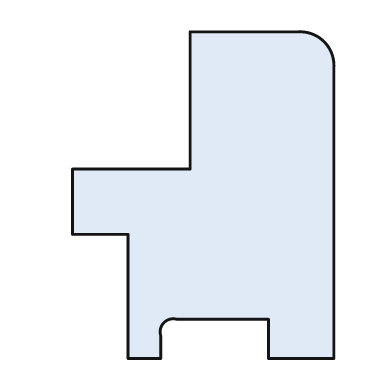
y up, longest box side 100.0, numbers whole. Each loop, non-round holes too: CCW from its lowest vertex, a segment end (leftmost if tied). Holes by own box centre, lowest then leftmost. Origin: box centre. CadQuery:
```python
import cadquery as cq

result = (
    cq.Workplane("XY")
    .moveTo(-23.0, -50.0)
    .lineTo(-13.0, -50.0)
    .lineTo(-13.0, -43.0)
    .threePointArc((-12.0, -39.0), (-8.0, -38.0))
    .lineTo(20.0, -38.0)
    .lineTo(20.0, -50.0)
    .lineTo(40.0, -50.0)
    .lineTo(40.0, 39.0)
    .threePointArc((37.0, 47.0), (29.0, 50.0))
    .lineTo(-4.0, 50.0)
    .lineTo(-4.0, 8.0)
    .lineTo(-40.0, 8.0)
    .lineTo(-40.0, -12.0)
    .lineTo(-23.0, -12.0)
    .close()
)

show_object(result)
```